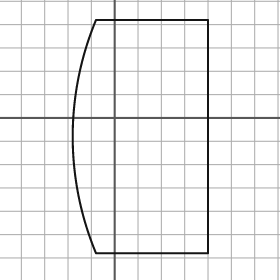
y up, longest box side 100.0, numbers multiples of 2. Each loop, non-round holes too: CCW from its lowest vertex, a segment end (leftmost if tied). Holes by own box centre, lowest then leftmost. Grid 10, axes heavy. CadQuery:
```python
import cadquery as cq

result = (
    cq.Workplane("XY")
    .moveTo(-8.0, -58.0)
    .lineTo(40.0, -58.0)
    .lineTo(40.0, 42.0)
    .lineTo(-8.0, 42.0)
    .threePointArc((-18.0, -8.0), (-8.0, -58.0))
    .close()
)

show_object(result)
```